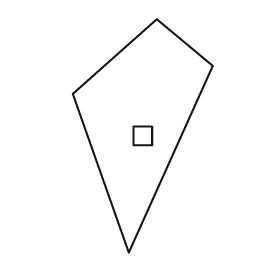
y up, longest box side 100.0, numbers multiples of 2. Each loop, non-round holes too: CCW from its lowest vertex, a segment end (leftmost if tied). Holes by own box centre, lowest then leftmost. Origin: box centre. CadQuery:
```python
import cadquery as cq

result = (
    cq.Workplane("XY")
    .moveTo(-6.0, -50.0)
    .lineTo(30.0, 30.0)
    .lineTo(6.0, 50.0)
    .lineTo(-30.0, 18.0)
    .close()
    .moveTo(-4.0, -4.0)
    .lineTo(4.0, -4.0)
    .lineTo(4.0, 4.0)
    .lineTo(-4.0, 4.0)
    .close()
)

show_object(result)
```